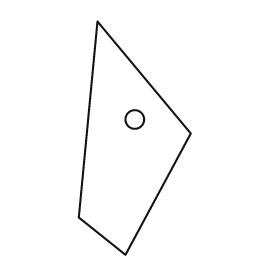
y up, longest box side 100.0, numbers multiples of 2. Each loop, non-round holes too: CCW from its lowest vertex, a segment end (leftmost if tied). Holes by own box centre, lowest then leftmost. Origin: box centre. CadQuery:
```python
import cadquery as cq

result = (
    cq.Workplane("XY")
    .moveTo(-4.0, -50.0)
    .lineTo(24.0, 2.0)
    .lineTo(-16.0, 50.0)
    .lineTo(-24.0, -34.0)
    .close()
    .moveTo(0.0, 8.0)
    .circle(4.0)
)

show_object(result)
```